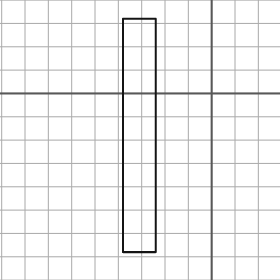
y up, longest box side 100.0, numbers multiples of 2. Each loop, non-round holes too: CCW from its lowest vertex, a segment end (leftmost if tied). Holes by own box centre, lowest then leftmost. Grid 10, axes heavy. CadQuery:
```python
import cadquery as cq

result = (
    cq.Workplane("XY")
    .moveTo(-38.0, -68.0)
    .lineTo(-24.0, -68.0)
    .lineTo(-24.0, 32.0)
    .lineTo(-38.0, 32.0)
    .close()
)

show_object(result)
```